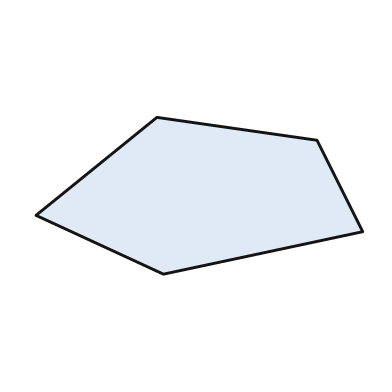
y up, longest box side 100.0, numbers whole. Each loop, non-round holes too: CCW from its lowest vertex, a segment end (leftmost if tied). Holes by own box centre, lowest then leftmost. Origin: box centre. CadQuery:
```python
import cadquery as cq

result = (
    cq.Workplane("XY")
    .moveTo(-11.0, -24.0)
    .lineTo(50.0, -11.0)
    .lineTo(36.0, 17.0)
    .lineTo(-13.0, 24.0)
    .lineTo(-50.0, -6.0)
    .close()
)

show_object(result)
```